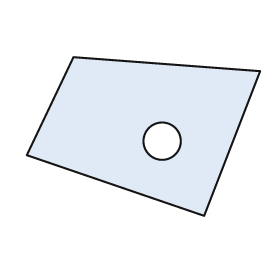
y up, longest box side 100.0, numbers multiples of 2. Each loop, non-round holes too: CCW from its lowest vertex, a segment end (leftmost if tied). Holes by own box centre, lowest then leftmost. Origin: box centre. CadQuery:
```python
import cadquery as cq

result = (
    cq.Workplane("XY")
    .moveTo(26.0, -34.0)
    .lineTo(50.0, 28.0)
    .lineTo(-30.0, 34.0)
    .lineTo(-50.0, -8.0)
    .close()
    .moveTo(8.0, -2.0)
    .circle(8.0)
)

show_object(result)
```